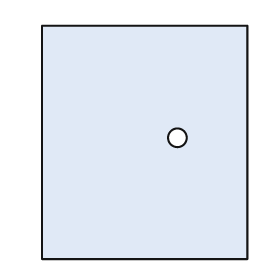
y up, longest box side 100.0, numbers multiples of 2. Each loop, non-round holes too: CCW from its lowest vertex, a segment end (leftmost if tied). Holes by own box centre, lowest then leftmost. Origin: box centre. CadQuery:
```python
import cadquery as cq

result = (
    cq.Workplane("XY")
    .moveTo(-44.0, -50.0)
    .lineTo(44.0, -50.0)
    .lineTo(44.0, 50.0)
    .lineTo(-44.0, 50.0)
    .close()
    .moveTo(14.0, 2.0)
    .circle(4.0)
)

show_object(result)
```